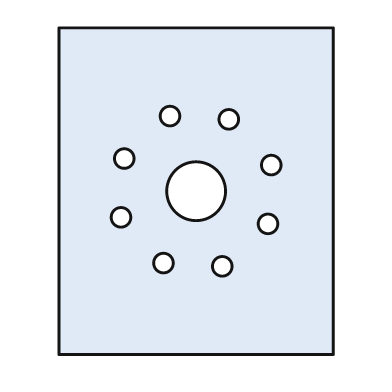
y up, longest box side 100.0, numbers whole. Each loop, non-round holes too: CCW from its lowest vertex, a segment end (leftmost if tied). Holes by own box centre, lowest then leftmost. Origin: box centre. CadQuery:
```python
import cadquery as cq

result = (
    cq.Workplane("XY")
    .moveTo(-42.0, -50.0)
    .lineTo(42.0, -50.0)
    .lineTo(42.0, 50.0)
    .lineTo(-42.0, 50.0)
    .close()
    .moveTo(8.0, -23.0)
    .circle(3.0)
    .moveTo(-10.0, -22.0)
    .circle(3.0)
    .moveTo(22.0, -10.0)
    .circle(3.0)
    .moveTo(-23.0, -8.0)
    .circle(3.0)
    .moveTo(0.0, 0.0)
    .circle(9.0)
    .moveTo(23.0, 8.0)
    .circle(3.0)
    .moveTo(-22.0, 10.0)
    .circle(3.0)
    .moveTo(10.0, 22.0)
    .circle(3.0)
    .moveTo(-8.0, 23.0)
    .circle(3.0)
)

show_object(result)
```